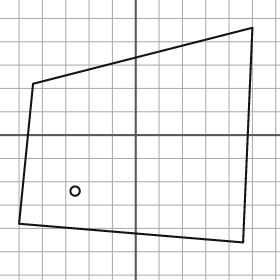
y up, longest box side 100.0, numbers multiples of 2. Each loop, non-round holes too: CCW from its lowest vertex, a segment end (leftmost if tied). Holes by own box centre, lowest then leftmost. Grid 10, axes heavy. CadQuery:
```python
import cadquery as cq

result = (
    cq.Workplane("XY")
    .moveTo(46.0, -46.0)
    .lineTo(50.0, 46.0)
    .lineTo(-44.0, 22.0)
    .lineTo(-50.0, -38.0)
    .close()
    .moveTo(-26.0, -24.0)
    .circle(2.0)
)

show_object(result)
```